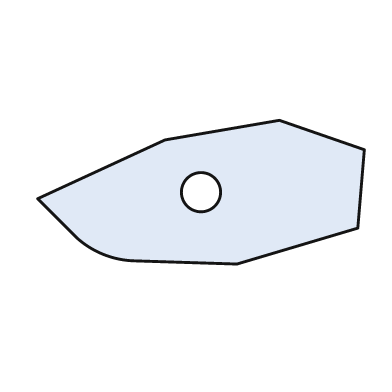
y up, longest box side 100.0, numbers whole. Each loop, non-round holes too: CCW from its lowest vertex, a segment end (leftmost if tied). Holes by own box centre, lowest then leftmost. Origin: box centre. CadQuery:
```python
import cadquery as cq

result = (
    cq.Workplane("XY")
    .moveTo(11.0, -22.0)
    .lineTo(48.0, -11.0)
    .lineTo(50.0, 13.0)
    .lineTo(24.0, 22.0)
    .lineTo(-11.0, 16.0)
    .lineTo(-50.0, -2.0)
    .lineTo(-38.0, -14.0)
    .threePointArc((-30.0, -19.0), (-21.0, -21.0))
    .close()
    .moveTo(0.0, 0.0)
    .circle(6.0)
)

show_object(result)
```